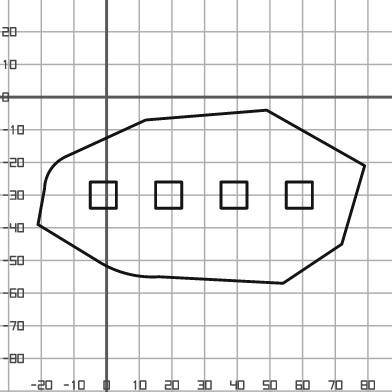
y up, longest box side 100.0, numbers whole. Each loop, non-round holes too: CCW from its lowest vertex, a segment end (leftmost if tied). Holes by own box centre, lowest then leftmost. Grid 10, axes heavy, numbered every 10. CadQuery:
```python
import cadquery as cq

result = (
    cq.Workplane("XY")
    .moveTo(54.0, -57.0)
    .lineTo(72.0, -45.0)
    .lineTo(79.0, -21.0)
    .lineTo(49.0, -4.0)
    .lineTo(12.0, -7.0)
    .lineTo(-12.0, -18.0)
    .threePointArc((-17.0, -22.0), (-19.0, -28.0))
    .lineTo(-21.0, -39.0)
    .lineTo(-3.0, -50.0)
    .threePointArc((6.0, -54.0), (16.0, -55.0))
    .close()
    .moveTo(-5.0, -34.0)
    .lineTo(3.0, -34.0)
    .lineTo(3.0, -26.0)
    .lineTo(-5.0, -26.0)
    .close()
    .moveTo(15.0, -34.0)
    .lineTo(23.0, -34.0)
    .lineTo(23.0, -26.0)
    .lineTo(15.0, -26.0)
    .close()
    .moveTo(35.0, -34.0)
    .lineTo(43.0, -34.0)
    .lineTo(43.0, -26.0)
    .lineTo(35.0, -26.0)
    .close()
    .moveTo(55.0, -34.0)
    .lineTo(63.0, -34.0)
    .lineTo(63.0, -26.0)
    .lineTo(55.0, -26.0)
    .close()
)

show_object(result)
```